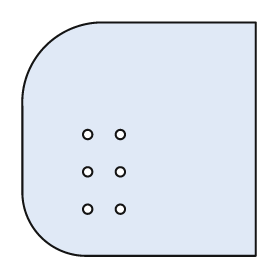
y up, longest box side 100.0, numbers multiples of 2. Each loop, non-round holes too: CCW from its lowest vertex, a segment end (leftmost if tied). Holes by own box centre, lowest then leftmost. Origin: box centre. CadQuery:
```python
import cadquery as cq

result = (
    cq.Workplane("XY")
    .moveTo(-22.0, -50.0)
    .lineTo(50.0, -50.0)
    .lineTo(50.0, 50.0)
    .lineTo(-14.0, 50.0)
    .threePointArc((-40.0, 40.0), (-50.0, 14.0))
    .lineTo(-50.0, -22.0)
    .threePointArc((-42.0, -42.0), (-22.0, -50.0))
    .close()
    .moveTo(-22.0, -30.0)
    .circle(2.0)
    .moveTo(-8.0, -30.0)
    .circle(2.0)
    .moveTo(-22.0, -14.0)
    .circle(2.0)
    .moveTo(-8.0, -14.0)
    .circle(2.0)
    .moveTo(-22.0, 2.0)
    .circle(2.0)
    .moveTo(-8.0, 2.0)
    .circle(2.0)
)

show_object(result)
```